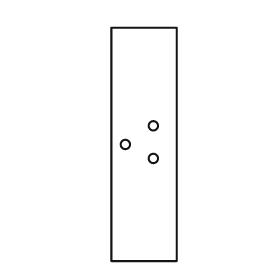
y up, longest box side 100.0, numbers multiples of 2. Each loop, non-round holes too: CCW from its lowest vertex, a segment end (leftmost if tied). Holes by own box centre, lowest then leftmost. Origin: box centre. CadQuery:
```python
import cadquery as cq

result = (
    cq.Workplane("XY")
    .moveTo(-14.0, -50.0)
    .lineTo(14.0, -50.0)
    .lineTo(14.0, 50.0)
    .lineTo(-14.0, 50.0)
    .close()
    .moveTo(4.0, -6.0)
    .circle(2.0)
    .moveTo(-8.0, 0.0)
    .circle(2.0)
    .moveTo(4.0, 8.0)
    .circle(2.0)
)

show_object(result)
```